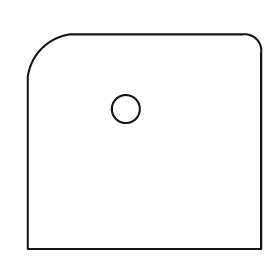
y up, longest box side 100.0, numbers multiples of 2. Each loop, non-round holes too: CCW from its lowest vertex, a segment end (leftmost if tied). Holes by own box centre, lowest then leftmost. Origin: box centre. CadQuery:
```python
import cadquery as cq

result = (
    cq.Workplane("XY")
    .moveTo(-50.0, -46.0)
    .lineTo(50.0, -46.0)
    .lineTo(50.0, 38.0)
    .threePointArc((48.0, 44.0), (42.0, 46.0))
    .lineTo(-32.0, 46.0)
    .threePointArc((-44.0, 40.0), (-50.0, 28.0))
    .close()
    .moveTo(-8.0, 14.0)
    .circle(6.0)
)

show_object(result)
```